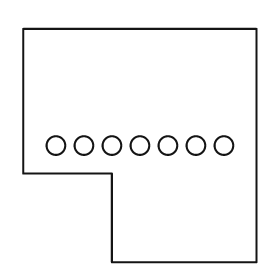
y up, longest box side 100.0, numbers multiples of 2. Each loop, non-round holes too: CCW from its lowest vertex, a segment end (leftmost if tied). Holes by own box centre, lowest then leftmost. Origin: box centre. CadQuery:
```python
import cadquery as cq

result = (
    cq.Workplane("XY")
    .moveTo(-12.0, -50.0)
    .lineTo(50.0, -50.0)
    .lineTo(50.0, 50.0)
    .lineTo(-50.0, 50.0)
    .lineTo(-50.0, -12.0)
    .lineTo(-12.0, -12.0)
    .close()
    .moveTo(-36.0, 0.0)
    .circle(4.0)
    .moveTo(-24.0, 0.0)
    .circle(4.0)
    .moveTo(-12.0, 0.0)
    .circle(4.0)
    .moveTo(0.0, 0.0)
    .circle(4.0)
    .moveTo(12.0, 0.0)
    .circle(4.0)
    .moveTo(24.0, 0.0)
    .circle(4.0)
    .moveTo(36.0, 0.0)
    .circle(4.0)
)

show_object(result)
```